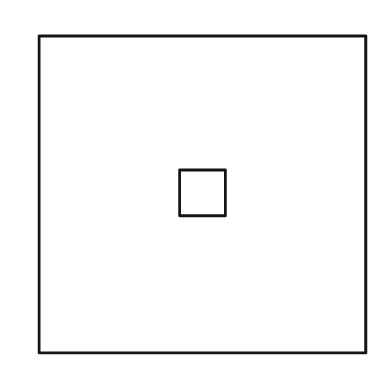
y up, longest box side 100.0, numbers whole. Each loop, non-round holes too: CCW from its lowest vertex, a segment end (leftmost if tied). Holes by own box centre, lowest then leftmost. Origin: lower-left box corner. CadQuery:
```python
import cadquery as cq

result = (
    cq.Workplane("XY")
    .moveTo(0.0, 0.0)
    .lineTo(100.0, 0.0)
    .lineTo(100.0, 97.0)
    .lineTo(0.0, 97.0)
    .close()
    .moveTo(43.0, 42.0)
    .lineTo(57.0, 42.0)
    .lineTo(57.0, 56.0)
    .lineTo(43.0, 56.0)
    .close()
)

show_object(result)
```